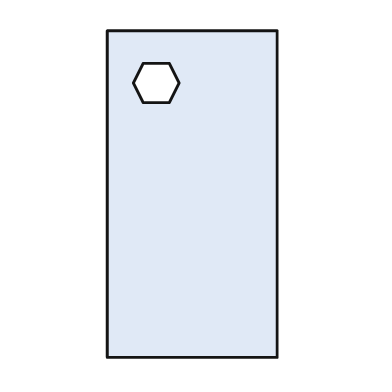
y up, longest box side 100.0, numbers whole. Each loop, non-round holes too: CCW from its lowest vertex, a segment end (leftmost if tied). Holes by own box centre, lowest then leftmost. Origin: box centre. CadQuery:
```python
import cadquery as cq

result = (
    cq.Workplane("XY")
    .moveTo(-26.0, -50.0)
    .lineTo(26.0, -50.0)
    .lineTo(26.0, 50.0)
    .lineTo(-26.0, 50.0)
    .close()
    .moveTo(-15.0, 28.0)
    .lineTo(-7.0, 28.0)
    .lineTo(-4.0, 34.0)
    .lineTo(-7.0, 40.0)
    .lineTo(-15.0, 40.0)
    .lineTo(-18.0, 34.0)
    .close()
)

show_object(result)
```